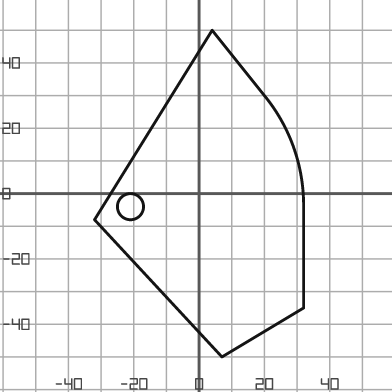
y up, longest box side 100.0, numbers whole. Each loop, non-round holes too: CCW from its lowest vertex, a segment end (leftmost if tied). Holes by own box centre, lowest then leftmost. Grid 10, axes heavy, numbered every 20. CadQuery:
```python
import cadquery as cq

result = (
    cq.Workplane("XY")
    .moveTo(7.0, -50.0)
    .lineTo(32.0, -35.0)
    .lineTo(32.0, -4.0)
    .threePointArc((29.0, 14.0), (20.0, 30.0))
    .lineTo(4.0, 50.0)
    .lineTo(-32.0, -8.0)
    .close()
    .moveTo(-21.0, -4.0)
    .circle(4.0)
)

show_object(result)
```